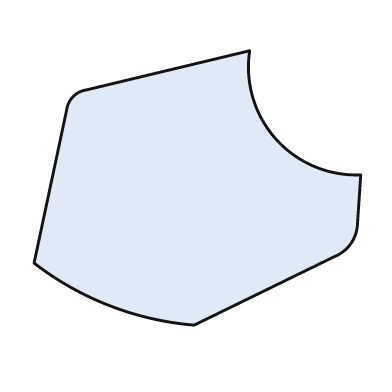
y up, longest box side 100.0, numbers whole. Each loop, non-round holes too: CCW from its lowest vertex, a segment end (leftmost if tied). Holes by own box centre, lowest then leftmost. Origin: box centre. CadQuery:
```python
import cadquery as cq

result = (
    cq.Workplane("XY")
    .moveTo(-1.0, -42.0)
    .lineTo(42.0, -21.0)
    .threePointArc((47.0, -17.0), (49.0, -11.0))
    .lineTo(50.0, 4.0)
    .threePointArc((24.0, 15.0), (16.0, 42.0))
    .lineTo(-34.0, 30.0)
    .threePointArc((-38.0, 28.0), (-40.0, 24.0))
    .lineTo(-50.0, -23.0)
    .threePointArc((-27.0, -36.0), (-1.0, -42.0))
    .close()
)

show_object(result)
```